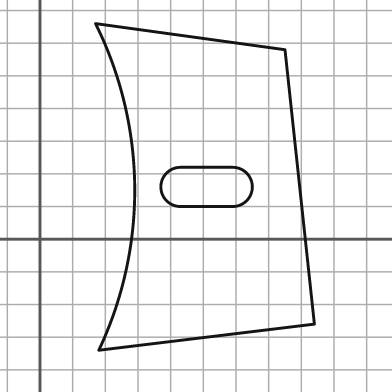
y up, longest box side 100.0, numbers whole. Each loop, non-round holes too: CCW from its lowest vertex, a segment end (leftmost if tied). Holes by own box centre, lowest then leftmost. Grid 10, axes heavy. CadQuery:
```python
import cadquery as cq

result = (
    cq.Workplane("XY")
    .moveTo(18.0, -34.0)
    .lineTo(84.0, -26.0)
    .lineTo(75.0, 58.0)
    .lineTo(17.0, 66.0)
    .threePointArc((29.0, 16.0), (18.0, -34.0))
    .close()
    .moveTo(43.0, 10.0)
    .lineTo(59.0, 10.0)
    .threePointArc((65.0, 16.0), (59.0, 22.0))
    .lineTo(43.0, 22.0)
    .threePointArc((37.0, 16.0), (43.0, 10.0))
    .close()
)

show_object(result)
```